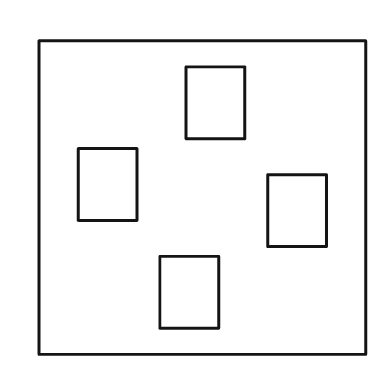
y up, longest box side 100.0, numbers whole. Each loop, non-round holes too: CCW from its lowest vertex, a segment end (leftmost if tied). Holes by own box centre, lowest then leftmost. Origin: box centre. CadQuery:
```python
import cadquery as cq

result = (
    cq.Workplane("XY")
    .moveTo(-50.0, -48.0)
    .lineTo(50.0, -48.0)
    .lineTo(50.0, 48.0)
    .lineTo(-50.0, 48.0)
    .close()
    .moveTo(-13.0, -40.0)
    .lineTo(5.0, -40.0)
    .lineTo(5.0, -18.0)
    .lineTo(-13.0, -18.0)
    .close()
    .moveTo(20.0, -15.0)
    .lineTo(38.0, -15.0)
    .lineTo(38.0, 7.0)
    .lineTo(20.0, 7.0)
    .close()
    .moveTo(-38.0, -7.0)
    .lineTo(-20.0, -7.0)
    .lineTo(-20.0, 15.0)
    .lineTo(-38.0, 15.0)
    .close()
    .moveTo(-5.0, 18.0)
    .lineTo(13.0, 18.0)
    .lineTo(13.0, 40.0)
    .lineTo(-5.0, 40.0)
    .close()
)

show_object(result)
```